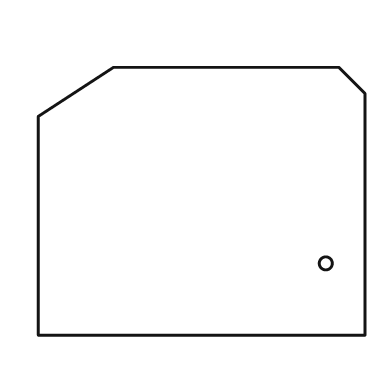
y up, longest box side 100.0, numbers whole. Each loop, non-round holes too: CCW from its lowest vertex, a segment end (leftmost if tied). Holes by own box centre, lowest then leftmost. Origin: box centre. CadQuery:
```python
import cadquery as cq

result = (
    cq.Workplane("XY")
    .moveTo(-50.0, -41.0)
    .lineTo(50.0, -41.0)
    .lineTo(50.0, 33.0)
    .lineTo(42.0, 41.0)
    .lineTo(-27.0, 41.0)
    .lineTo(-50.0, 26.0)
    .close()
    .moveTo(38.0, -19.0)
    .circle(2.0)
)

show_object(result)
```